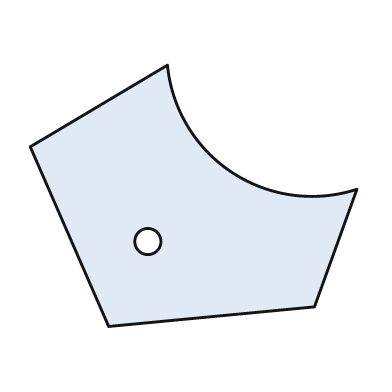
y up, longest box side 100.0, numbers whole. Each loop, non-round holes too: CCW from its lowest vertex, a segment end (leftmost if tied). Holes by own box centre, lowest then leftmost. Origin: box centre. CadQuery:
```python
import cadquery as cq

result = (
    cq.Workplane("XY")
    .moveTo(-26.0, -40.0)
    .lineTo(37.0, -34.0)
    .lineTo(50.0, 2.0)
    .threePointArc((12.0, 7.0), (-8.0, 40.0))
    .lineTo(-50.0, 15.0)
    .close()
    .moveTo(-14.0, -14.0)
    .circle(4.0)
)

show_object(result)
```